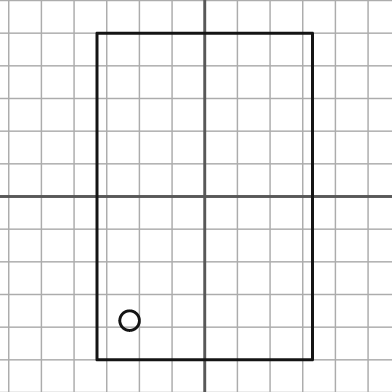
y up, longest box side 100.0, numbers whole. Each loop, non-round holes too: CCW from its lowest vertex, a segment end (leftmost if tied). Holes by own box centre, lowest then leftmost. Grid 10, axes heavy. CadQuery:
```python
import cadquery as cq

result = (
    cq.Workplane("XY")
    .moveTo(-33.0, -50.0)
    .lineTo(33.0, -50.0)
    .lineTo(33.0, 50.0)
    .lineTo(-33.0, 50.0)
    .close()
    .moveTo(-23.0, -38.0)
    .circle(3.0)
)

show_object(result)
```